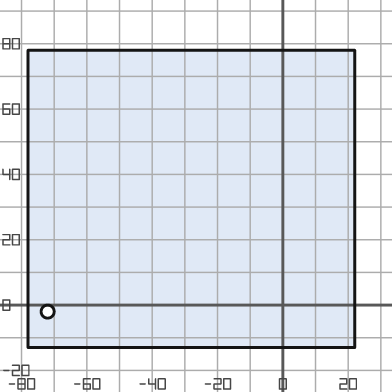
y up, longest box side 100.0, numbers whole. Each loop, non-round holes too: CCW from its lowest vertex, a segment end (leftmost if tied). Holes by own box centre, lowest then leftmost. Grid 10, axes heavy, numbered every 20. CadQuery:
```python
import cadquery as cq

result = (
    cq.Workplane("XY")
    .moveTo(-78.0, -13.0)
    .lineTo(22.0, -13.0)
    .lineTo(22.0, 78.0)
    .lineTo(-78.0, 78.0)
    .close()
    .moveTo(-72.0, -2.0)
    .circle(2.0)
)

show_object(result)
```